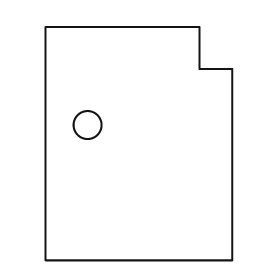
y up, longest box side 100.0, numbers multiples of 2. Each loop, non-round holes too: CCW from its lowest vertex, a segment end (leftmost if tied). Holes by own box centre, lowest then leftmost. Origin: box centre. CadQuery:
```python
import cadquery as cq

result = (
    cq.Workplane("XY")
    .moveTo(-40.0, -50.0)
    .lineTo(40.0, -50.0)
    .lineTo(40.0, 32.0)
    .lineTo(26.0, 32.0)
    .lineTo(26.0, 50.0)
    .lineTo(-40.0, 50.0)
    .close()
    .moveTo(-22.0, 8.0)
    .circle(6.0)
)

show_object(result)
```